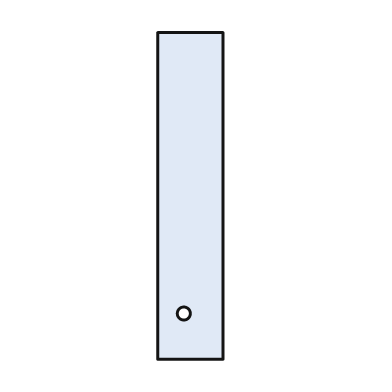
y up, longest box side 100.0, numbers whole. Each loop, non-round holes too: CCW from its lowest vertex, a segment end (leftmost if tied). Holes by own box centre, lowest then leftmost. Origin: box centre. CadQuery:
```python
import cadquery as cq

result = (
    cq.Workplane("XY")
    .moveTo(-10.0, -50.0)
    .lineTo(10.0, -50.0)
    .lineTo(10.0, 50.0)
    .lineTo(-10.0, 50.0)
    .close()
    .moveTo(-2.0, -36.0)
    .circle(2.0)
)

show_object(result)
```